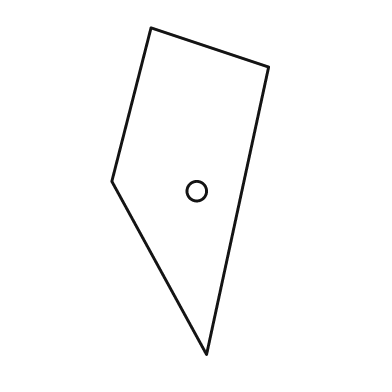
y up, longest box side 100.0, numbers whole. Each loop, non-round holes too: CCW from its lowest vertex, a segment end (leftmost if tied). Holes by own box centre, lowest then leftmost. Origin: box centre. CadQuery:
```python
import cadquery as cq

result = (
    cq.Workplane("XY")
    .moveTo(5.0, -50.0)
    .lineTo(24.0, 38.0)
    .lineTo(-12.0, 50.0)
    .lineTo(-24.0, 3.0)
    .close()
    .moveTo(2.0, 0.0)
    .circle(3.0)
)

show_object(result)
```